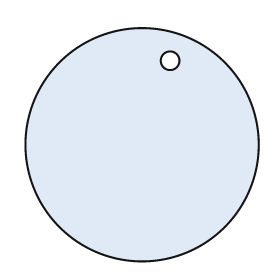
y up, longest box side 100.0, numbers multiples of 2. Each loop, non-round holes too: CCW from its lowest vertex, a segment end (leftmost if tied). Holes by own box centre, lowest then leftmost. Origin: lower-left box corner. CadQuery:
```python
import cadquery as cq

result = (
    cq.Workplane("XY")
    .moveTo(50.0, 50.0)
    .circle(50.0)
    .moveTo(62.0, 86.0)
    .circle(4.0)
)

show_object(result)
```